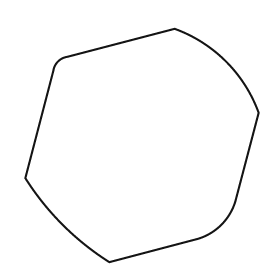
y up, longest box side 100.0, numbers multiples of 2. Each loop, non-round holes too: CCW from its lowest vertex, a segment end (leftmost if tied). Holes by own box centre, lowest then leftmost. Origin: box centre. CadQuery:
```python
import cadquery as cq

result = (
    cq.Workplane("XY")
    .moveTo(-14.0, -50.0)
    .lineTo(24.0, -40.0)
    .threePointArc((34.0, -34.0), (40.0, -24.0))
    .lineTo(50.0, 14.0)
    .threePointArc((36.0, 36.0), (14.0, 50.0))
    .lineTo(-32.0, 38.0)
    .threePointArc((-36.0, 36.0), (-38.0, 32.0))
    .lineTo(-50.0, -14.0)
    .threePointArc((-34.0, -34.0), (-14.0, -50.0))
    .close()
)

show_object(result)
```